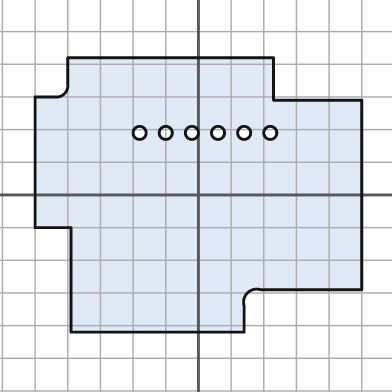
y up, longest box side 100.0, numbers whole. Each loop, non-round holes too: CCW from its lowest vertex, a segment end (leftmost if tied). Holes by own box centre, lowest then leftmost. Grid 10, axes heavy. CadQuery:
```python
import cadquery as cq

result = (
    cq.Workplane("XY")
    .moveTo(-39.0, -42.0)
    .lineTo(14.0, -42.0)
    .lineTo(14.0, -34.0)
    .threePointArc((15.0, -30.0), (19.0, -29.0))
    .lineTo(50.0, -29.0)
    .lineTo(50.0, 29.0)
    .lineTo(23.0, 29.0)
    .lineTo(23.0, 42.0)
    .lineTo(-40.0, 42.0)
    .lineTo(-40.0, 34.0)
    .threePointArc((-41.0, 31.0), (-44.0, 30.0))
    .lineTo(-50.0, 30.0)
    .lineTo(-50.0, -10.0)
    .lineTo(-39.0, -10.0)
    .close()
    .moveTo(-18.0, 19.0)
    .circle(2.0)
    .moveTo(-10.0, 19.0)
    .circle(2.0)
    .moveTo(-2.0, 19.0)
    .circle(2.0)
    .moveTo(6.0, 19.0)
    .circle(2.0)
    .moveTo(14.0, 19.0)
    .circle(2.0)
    .moveTo(22.0, 19.0)
    .circle(2.0)
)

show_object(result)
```